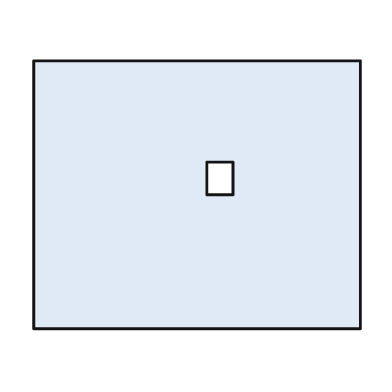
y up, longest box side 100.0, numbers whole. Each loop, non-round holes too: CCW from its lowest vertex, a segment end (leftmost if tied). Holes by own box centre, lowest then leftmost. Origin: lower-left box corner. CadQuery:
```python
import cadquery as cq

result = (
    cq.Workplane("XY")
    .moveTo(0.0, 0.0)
    .lineTo(100.0, 0.0)
    .lineTo(100.0, 82.0)
    .lineTo(0.0, 82.0)
    .close()
    .moveTo(53.0, 41.0)
    .lineTo(61.0, 41.0)
    .lineTo(61.0, 51.0)
    .lineTo(53.0, 51.0)
    .close()
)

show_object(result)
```